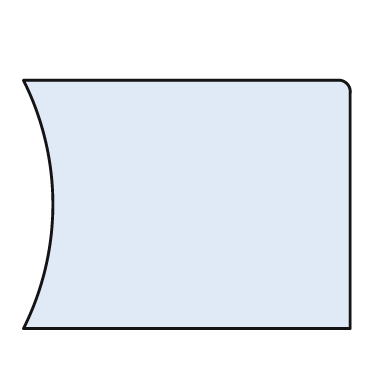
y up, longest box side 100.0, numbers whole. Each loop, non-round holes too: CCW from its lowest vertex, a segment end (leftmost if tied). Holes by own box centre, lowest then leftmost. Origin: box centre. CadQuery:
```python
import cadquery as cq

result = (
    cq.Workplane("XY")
    .moveTo(-50.0, -38.0)
    .lineTo(50.0, -38.0)
    .lineTo(50.0, 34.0)
    .threePointArc((49.0, 37.0), (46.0, 38.0))
    .lineTo(-50.0, 38.0)
    .threePointArc((-41.0, 0.0), (-50.0, -38.0))
    .close()
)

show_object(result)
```